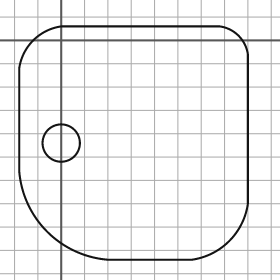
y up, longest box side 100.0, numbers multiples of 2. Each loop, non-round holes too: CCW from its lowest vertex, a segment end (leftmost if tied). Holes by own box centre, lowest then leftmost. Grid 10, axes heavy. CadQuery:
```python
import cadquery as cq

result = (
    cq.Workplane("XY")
    .moveTo(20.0, -94.0)
    .lineTo(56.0, -94.0)
    .threePointArc((72.0, -86.0), (80.0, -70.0))
    .lineTo(80.0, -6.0)
    .threePointArc((76.0, 2.0), (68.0, 6.0))
    .lineTo(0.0, 6.0)
    .threePointArc((-12.0, 0.0), (-18.0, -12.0))
    .lineTo(-18.0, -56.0)
    .threePointArc((-6.0, -82.0), (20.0, -94.0))
    .close()
    .moveTo(0.0, -44.0)
    .circle(8.0)
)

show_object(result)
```